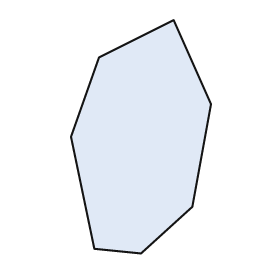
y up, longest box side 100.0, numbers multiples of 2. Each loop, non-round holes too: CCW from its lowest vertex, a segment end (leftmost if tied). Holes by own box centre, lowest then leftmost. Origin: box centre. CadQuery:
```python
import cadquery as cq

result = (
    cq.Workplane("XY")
    .moveTo(0.0, -50.0)
    .lineTo(22.0, -30.0)
    .lineTo(30.0, 14.0)
    .lineTo(14.0, 50.0)
    .lineTo(-18.0, 34.0)
    .lineTo(-30.0, 0.0)
    .lineTo(-20.0, -48.0)
    .close()
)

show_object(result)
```